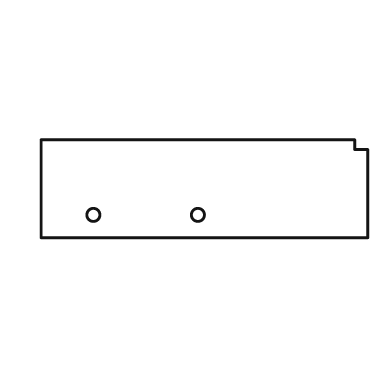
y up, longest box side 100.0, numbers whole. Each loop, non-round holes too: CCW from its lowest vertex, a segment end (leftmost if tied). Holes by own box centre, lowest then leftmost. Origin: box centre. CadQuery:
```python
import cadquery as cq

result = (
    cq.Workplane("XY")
    .moveTo(-50.0, -15.0)
    .lineTo(50.0, -15.0)
    .lineTo(50.0, 12.0)
    .lineTo(46.0, 12.0)
    .lineTo(46.0, 15.0)
    .lineTo(-50.0, 15.0)
    .close()
    .moveTo(-34.0, -8.0)
    .circle(2.0)
    .moveTo(-2.0, -8.0)
    .circle(2.0)
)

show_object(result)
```